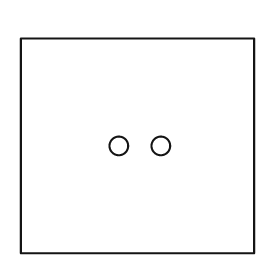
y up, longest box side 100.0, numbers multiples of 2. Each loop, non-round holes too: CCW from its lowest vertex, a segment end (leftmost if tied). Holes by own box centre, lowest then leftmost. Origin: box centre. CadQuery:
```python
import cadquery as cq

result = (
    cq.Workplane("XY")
    .moveTo(-50.0, -46.0)
    .lineTo(50.0, -46.0)
    .lineTo(50.0, 46.0)
    .lineTo(-50.0, 46.0)
    .close()
    .moveTo(-8.0, 0.0)
    .circle(4.0)
    .moveTo(10.0, 0.0)
    .circle(4.0)
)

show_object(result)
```